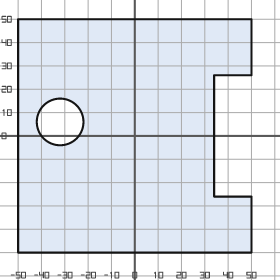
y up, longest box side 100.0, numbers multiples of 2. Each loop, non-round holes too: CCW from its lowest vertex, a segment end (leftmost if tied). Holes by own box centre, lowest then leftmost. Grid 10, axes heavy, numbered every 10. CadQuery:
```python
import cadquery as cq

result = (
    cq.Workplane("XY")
    .moveTo(-50.0, -50.0)
    .lineTo(50.0, -50.0)
    .lineTo(50.0, -26.0)
    .lineTo(34.0, -26.0)
    .lineTo(34.0, 26.0)
    .lineTo(50.0, 26.0)
    .lineTo(50.0, 50.0)
    .lineTo(-50.0, 50.0)
    .close()
    .moveTo(-32.0, 6.0)
    .circle(10.0)
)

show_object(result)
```